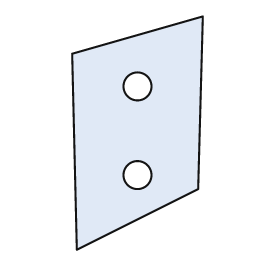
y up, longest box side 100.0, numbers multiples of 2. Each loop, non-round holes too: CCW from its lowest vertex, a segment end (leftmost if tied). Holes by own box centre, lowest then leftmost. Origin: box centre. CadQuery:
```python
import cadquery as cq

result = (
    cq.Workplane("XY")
    .moveTo(-26.0, -50.0)
    .lineTo(26.0, -24.0)
    .lineTo(28.0, 50.0)
    .lineTo(-28.0, 34.0)
    .close()
    .moveTo(0.0, -18.0)
    .circle(6.0)
    .moveTo(0.0, 20.0)
    .circle(6.0)
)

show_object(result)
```